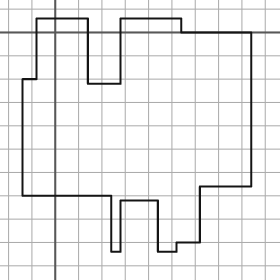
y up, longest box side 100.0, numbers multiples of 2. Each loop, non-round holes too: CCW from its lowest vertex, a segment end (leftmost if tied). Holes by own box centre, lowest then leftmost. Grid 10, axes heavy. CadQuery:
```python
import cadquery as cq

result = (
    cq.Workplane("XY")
    .moveTo(24.0, -94.0)
    .lineTo(28.0, -94.0)
    .lineTo(28.0, -72.0)
    .lineTo(44.0, -72.0)
    .lineTo(44.0, -94.0)
    .lineTo(52.0, -94.0)
    .lineTo(52.0, -90.0)
    .lineTo(62.0, -90.0)
    .lineTo(62.0, -66.0)
    .lineTo(84.0, -66.0)
    .lineTo(84.0, 0.0)
    .lineTo(54.0, 0.0)
    .lineTo(54.0, 6.0)
    .lineTo(28.0, 6.0)
    .lineTo(28.0, -22.0)
    .lineTo(14.0, -22.0)
    .lineTo(14.0, 6.0)
    .lineTo(-8.0, 6.0)
    .lineTo(-8.0, -20.0)
    .lineTo(-14.0, -20.0)
    .lineTo(-14.0, -70.0)
    .lineTo(24.0, -70.0)
    .close()
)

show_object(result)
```